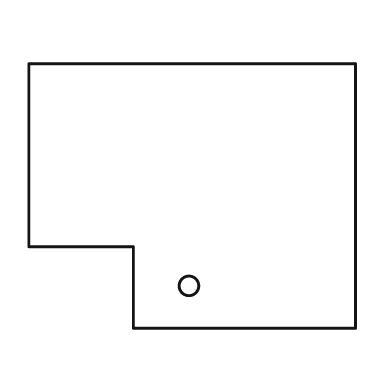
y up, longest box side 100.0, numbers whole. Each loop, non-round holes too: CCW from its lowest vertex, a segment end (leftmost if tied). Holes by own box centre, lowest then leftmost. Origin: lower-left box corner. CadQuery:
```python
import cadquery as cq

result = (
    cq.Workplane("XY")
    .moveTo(32.0, 0.0)
    .lineTo(100.0, 0.0)
    .lineTo(100.0, 81.0)
    .lineTo(0.0, 81.0)
    .lineTo(0.0, 25.0)
    .lineTo(32.0, 25.0)
    .close()
    .moveTo(49.0, 13.0)
    .circle(3.0)
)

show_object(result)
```